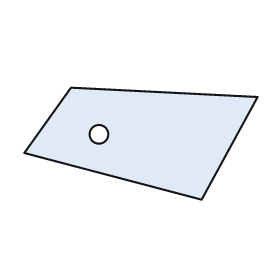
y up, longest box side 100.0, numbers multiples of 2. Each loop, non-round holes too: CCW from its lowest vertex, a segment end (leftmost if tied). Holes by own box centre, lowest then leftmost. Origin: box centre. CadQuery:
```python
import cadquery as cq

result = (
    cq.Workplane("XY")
    .moveTo(26.0, -24.0)
    .lineTo(50.0, 20.0)
    .lineTo(-30.0, 24.0)
    .lineTo(-50.0, -4.0)
    .close()
    .moveTo(-18.0, 4.0)
    .circle(4.0)
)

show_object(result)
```